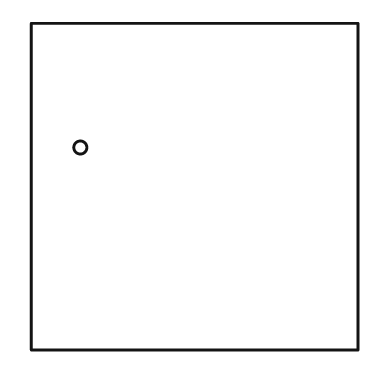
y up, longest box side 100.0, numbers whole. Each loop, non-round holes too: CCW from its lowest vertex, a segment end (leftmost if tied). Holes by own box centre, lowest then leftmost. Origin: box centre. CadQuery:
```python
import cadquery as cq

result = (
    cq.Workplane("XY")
    .moveTo(-50.0, -50.0)
    .lineTo(50.0, -50.0)
    .lineTo(50.0, 50.0)
    .lineTo(-50.0, 50.0)
    .close()
    .moveTo(-35.0, 12.0)
    .circle(2.0)
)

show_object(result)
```